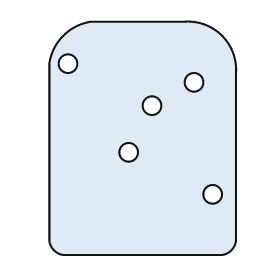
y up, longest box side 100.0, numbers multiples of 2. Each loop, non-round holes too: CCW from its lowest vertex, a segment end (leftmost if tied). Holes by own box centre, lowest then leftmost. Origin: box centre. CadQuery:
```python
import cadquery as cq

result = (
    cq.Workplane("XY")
    .moveTo(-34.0, -50.0)
    .lineTo(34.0, -50.0)
    .threePointArc((38.0, -48.0), (40.0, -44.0))
    .lineTo(40.0, 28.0)
    .threePointArc((34.0, 44.0), (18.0, 50.0))
    .lineTo(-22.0, 50.0)
    .threePointArc((-34.0, 44.0), (-40.0, 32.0))
    .lineTo(-40.0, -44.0)
    .threePointArc((-38.0, -48.0), (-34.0, -50.0))
    .close()
    .moveTo(30.0, -24.0)
    .circle(4.0)
    .moveTo(-6.0, -6.0)
    .circle(4.0)
    .moveTo(4.0, 14.0)
    .circle(4.0)
    .moveTo(22.0, 24.0)
    .circle(4.0)
    .moveTo(-32.0, 32.0)
    .circle(4.0)
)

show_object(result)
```